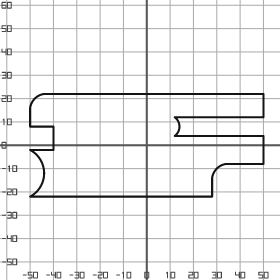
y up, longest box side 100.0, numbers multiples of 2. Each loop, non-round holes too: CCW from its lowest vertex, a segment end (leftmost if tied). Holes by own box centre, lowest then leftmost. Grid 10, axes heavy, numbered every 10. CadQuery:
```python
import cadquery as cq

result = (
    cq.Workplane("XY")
    .moveTo(-50.0, -22.0)
    .lineTo(28.0, -22.0)
    .lineTo(28.0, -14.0)
    .threePointArc((30.0, -10.0), (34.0, -8.0))
    .lineTo(50.0, -8.0)
    .lineTo(50.0, 4.0)
    .lineTo(12.0, 4.0)
    .threePointArc((14.0, 8.0), (12.0, 12.0))
    .lineTo(50.0, 12.0)
    .lineTo(50.0, 22.0)
    .lineTo(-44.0, 22.0)
    .threePointArc((-48.0, 20.0), (-50.0, 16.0))
    .lineTo(-50.0, 8.0)
    .lineTo(-40.0, 8.0)
    .lineTo(-40.0, -2.0)
    .lineTo(-50.0, -2.0)
    .threePointArc((-44.0, -12.0), (-50.0, -22.0))
    .close()
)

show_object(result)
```